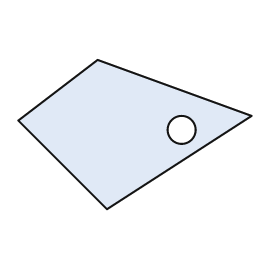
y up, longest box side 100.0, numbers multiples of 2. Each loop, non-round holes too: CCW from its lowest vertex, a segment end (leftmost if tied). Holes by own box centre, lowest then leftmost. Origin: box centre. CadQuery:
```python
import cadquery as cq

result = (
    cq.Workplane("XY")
    .moveTo(-12.0, -32.0)
    .lineTo(50.0, 8.0)
    .lineTo(-16.0, 32.0)
    .lineTo(-50.0, 6.0)
    .close()
    .moveTo(20.0, 2.0)
    .circle(6.0)
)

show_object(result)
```